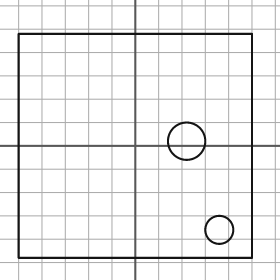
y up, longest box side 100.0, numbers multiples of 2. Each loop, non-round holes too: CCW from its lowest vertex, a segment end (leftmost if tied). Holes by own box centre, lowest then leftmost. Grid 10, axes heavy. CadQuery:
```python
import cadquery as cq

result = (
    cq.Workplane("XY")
    .moveTo(-50.0, -48.0)
    .lineTo(50.0, -48.0)
    .lineTo(50.0, 48.0)
    .lineTo(-50.0, 48.0)
    .close()
    .moveTo(36.0, -36.0)
    .circle(6.0)
    .moveTo(22.0, 2.0)
    .circle(8.0)
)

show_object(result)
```